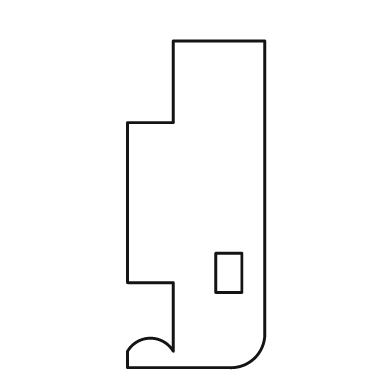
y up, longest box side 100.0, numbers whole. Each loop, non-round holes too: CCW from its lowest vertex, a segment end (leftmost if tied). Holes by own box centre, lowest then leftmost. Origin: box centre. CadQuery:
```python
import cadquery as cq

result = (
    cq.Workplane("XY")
    .moveTo(-21.0, -50.0)
    .lineTo(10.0, -50.0)
    .threePointArc((18.0, -47.0), (21.0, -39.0))
    .lineTo(21.0, 50.0)
    .lineTo(-7.0, 50.0)
    .lineTo(-7.0, 25.0)
    .lineTo(-21.0, 25.0)
    .lineTo(-21.0, -24.0)
    .lineTo(-7.0, -24.0)
    .lineTo(-7.0, -45.0)
    .threePointArc((-14.0, -41.0), (-21.0, -45.0))
    .close()
    .moveTo(6.0, -27.0)
    .lineTo(14.0, -27.0)
    .lineTo(14.0, -15.0)
    .lineTo(6.0, -15.0)
    .close()
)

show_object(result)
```